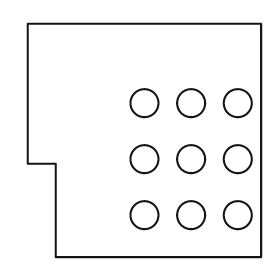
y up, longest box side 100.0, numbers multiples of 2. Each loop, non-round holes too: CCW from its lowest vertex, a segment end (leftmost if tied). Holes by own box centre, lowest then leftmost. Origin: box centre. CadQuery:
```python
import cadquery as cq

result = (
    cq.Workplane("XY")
    .moveTo(-38.0, -50.0)
    .lineTo(50.0, -50.0)
    .lineTo(50.0, 50.0)
    .lineTo(-50.0, 50.0)
    .lineTo(-50.0, -10.0)
    .lineTo(-38.0, -10.0)
    .close()
    .moveTo(0.0, -32.0)
    .circle(6.0)
    .moveTo(20.0, -32.0)
    .circle(6.0)
    .moveTo(40.0, -32.0)
    .circle(6.0)
    .moveTo(0.0, -8.0)
    .circle(6.0)
    .moveTo(20.0, -8.0)
    .circle(6.0)
    .moveTo(40.0, -8.0)
    .circle(6.0)
    .moveTo(0.0, 16.0)
    .circle(6.0)
    .moveTo(20.0, 16.0)
    .circle(6.0)
    .moveTo(40.0, 16.0)
    .circle(6.0)
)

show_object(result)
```